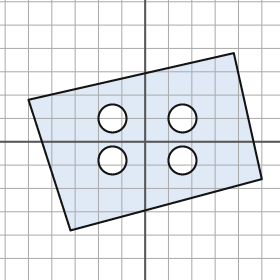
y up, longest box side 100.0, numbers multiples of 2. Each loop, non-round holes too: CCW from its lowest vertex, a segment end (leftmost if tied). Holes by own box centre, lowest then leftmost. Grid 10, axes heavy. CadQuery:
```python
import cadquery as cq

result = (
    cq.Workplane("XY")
    .moveTo(-32.0, -38.0)
    .lineTo(50.0, -16.0)
    .lineTo(38.0, 38.0)
    .lineTo(-50.0, 18.0)
    .close()
    .moveTo(-14.0, -8.0)
    .circle(6.0)
    .moveTo(16.0, -8.0)
    .circle(6.0)
    .moveTo(-14.0, 10.0)
    .circle(6.0)
    .moveTo(16.0, 10.0)
    .circle(6.0)
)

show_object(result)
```